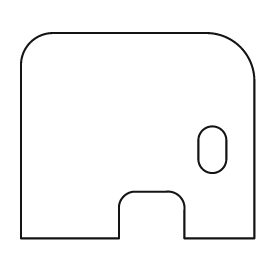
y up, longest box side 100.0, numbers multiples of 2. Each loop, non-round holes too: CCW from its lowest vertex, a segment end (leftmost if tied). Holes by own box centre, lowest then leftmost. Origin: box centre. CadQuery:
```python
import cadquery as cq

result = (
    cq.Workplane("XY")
    .moveTo(-50.0, -44.0)
    .lineTo(-8.0, -44.0)
    .lineTo(-8.0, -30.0)
    .threePointArc((-6.0, -26.0), (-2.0, -24.0))
    .lineTo(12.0, -24.0)
    .threePointArc((18.0, -26.0), (20.0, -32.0))
    .lineTo(20.0, -44.0)
    .lineTo(50.0, -44.0)
    .lineTo(50.0, 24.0)
    .threePointArc((44.0, 38.0), (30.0, 44.0))
    .lineTo(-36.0, 44.0)
    .threePointArc((-46.0, 40.0), (-50.0, 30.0))
    .close()
    .moveTo(26.0, -10.0)
    .threePointArc((32.0, -16.0), (38.0, -10.0))
    .lineTo(38.0, -2.0)
    .threePointArc((32.0, 4.0), (26.0, -2.0))
    .close()
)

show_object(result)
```